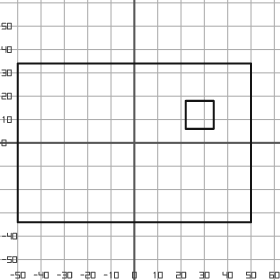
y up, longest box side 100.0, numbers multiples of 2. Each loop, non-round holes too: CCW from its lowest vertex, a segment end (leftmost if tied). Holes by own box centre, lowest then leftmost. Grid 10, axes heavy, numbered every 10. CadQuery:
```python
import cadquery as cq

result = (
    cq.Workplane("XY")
    .moveTo(-50.0, -34.0)
    .lineTo(50.0, -34.0)
    .lineTo(50.0, 34.0)
    .lineTo(-50.0, 34.0)
    .close()
    .moveTo(22.0, 6.0)
    .lineTo(34.0, 6.0)
    .lineTo(34.0, 18.0)
    .lineTo(22.0, 18.0)
    .close()
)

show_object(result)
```